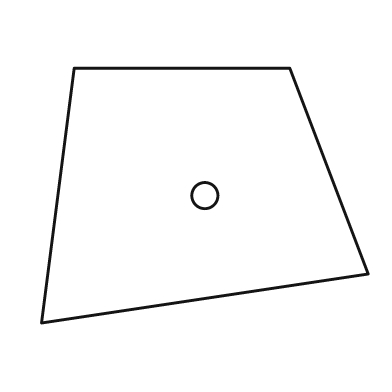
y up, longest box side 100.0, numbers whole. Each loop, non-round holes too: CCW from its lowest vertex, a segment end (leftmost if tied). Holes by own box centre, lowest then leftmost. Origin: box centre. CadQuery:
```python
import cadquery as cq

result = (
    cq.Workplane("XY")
    .moveTo(-50.0, -39.0)
    .lineTo(50.0, -24.0)
    .lineTo(26.0, 39.0)
    .lineTo(-40.0, 39.0)
    .close()
    .moveTo(0.0, 0.0)
    .circle(4.0)
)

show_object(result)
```